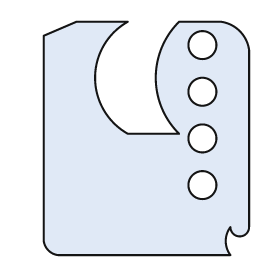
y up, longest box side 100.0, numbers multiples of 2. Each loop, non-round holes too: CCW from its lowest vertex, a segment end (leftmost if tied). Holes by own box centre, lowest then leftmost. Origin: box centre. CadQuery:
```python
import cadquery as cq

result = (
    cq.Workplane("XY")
    .moveTo(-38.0, -50.0)
    .lineTo(36.0, -50.0)
    .threePointArc((34.0, -44.0), (36.0, -38.0))
    .threePointArc((40.0, -42.0), (44.0, -38.0))
    .lineTo(44.0, 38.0)
    .threePointArc((40.0, 46.0), (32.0, 50.0))
    .lineTo(14.0, 50.0)
    .threePointArc((4.0, 26.0), (14.0, 2.0))
    .lineTo(-8.0, 2.0)
    .threePointArc((-22.0, 26.0), (-8.0, 50.0))
    .lineTo(-30.0, 50.0)
    .lineTo(-44.0, 44.0)
    .lineTo(-44.0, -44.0)
    .threePointArc((-42.0, -48.0), (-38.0, -50.0))
    .close()
    .moveTo(24.0, -20.0)
    .circle(6.0)
    .moveTo(24.0, 0.0)
    .circle(6.0)
    .moveTo(24.0, 20.0)
    .circle(6.0)
    .moveTo(24.0, 40.0)
    .circle(6.0)
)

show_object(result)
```